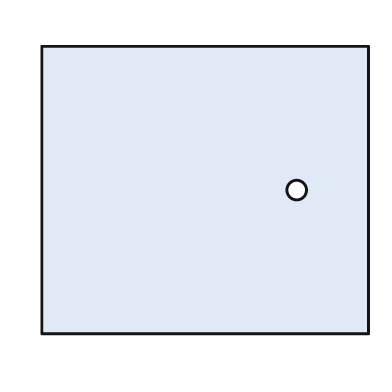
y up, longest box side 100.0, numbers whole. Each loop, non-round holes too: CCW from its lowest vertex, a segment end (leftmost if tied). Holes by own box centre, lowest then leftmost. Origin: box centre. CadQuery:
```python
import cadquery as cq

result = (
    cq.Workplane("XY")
    .moveTo(-50.0, -44.0)
    .lineTo(50.0, -44.0)
    .lineTo(50.0, 44.0)
    .lineTo(-50.0, 44.0)
    .close()
    .moveTo(28.0, 0.0)
    .circle(3.0)
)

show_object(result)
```